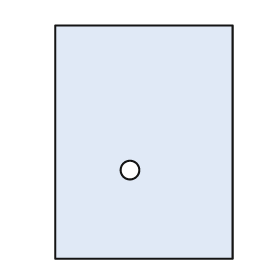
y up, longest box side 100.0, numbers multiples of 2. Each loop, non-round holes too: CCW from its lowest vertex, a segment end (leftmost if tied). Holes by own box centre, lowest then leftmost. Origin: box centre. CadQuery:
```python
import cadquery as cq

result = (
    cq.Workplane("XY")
    .moveTo(-38.0, -50.0)
    .lineTo(38.0, -50.0)
    .lineTo(38.0, 50.0)
    .lineTo(-38.0, 50.0)
    .close()
    .moveTo(-6.0, -12.0)
    .circle(4.0)
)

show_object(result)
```